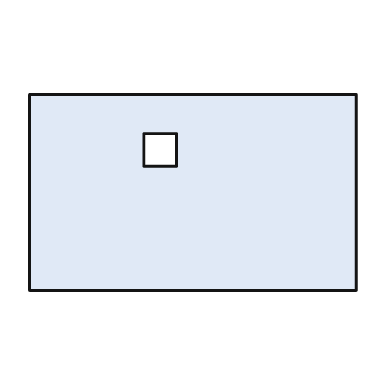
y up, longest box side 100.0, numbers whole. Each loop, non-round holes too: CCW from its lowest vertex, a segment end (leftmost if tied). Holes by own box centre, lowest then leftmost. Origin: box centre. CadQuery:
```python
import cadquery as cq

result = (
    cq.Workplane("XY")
    .moveTo(-50.0, -30.0)
    .lineTo(50.0, -30.0)
    .lineTo(50.0, 30.0)
    .lineTo(-50.0, 30.0)
    .close()
    .moveTo(-15.0, 8.0)
    .lineTo(-5.0, 8.0)
    .lineTo(-5.0, 18.0)
    .lineTo(-15.0, 18.0)
    .close()
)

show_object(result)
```